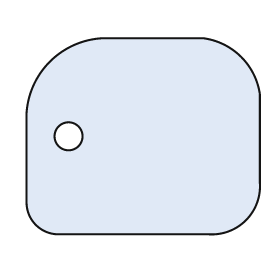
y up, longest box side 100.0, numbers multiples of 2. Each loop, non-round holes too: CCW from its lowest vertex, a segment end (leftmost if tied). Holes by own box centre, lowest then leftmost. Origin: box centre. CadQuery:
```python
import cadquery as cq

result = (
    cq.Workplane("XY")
    .moveTo(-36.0, -42.0)
    .lineTo(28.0, -42.0)
    .threePointArc((44.0, -36.0), (50.0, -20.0))
    .lineTo(50.0, 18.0)
    .threePointArc((42.0, 34.0), (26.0, 42.0))
    .lineTo(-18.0, 42.0)
    .threePointArc((-40.0, 32.0), (-50.0, 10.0))
    .lineTo(-50.0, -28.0)
    .threePointArc((-46.0, -38.0), (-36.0, -42.0))
    .close()
    .moveTo(-32.0, 0.0)
    .circle(6.0)
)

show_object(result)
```